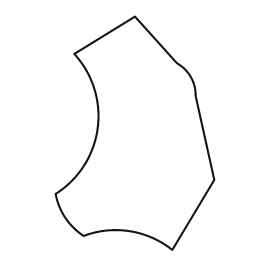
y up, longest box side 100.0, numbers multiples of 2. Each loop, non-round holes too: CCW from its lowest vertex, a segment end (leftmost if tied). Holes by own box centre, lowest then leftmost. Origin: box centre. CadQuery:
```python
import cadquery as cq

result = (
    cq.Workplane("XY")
    .moveTo(16.0, -50.0)
    .lineTo(34.0, -20.0)
    .lineTo(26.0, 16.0)
    .threePointArc((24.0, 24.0), (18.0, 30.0))
    .lineTo(0.0, 50.0)
    .lineTo(-26.0, 34.0)
    .threePointArc((-16.0, 2.0), (-34.0, -26.0))
    .threePointArc((-30.0, -36.0), (-22.0, -44.0))
    .threePointArc((-2.0, -42.0), (16.0, -50.0))
    .close()
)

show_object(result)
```